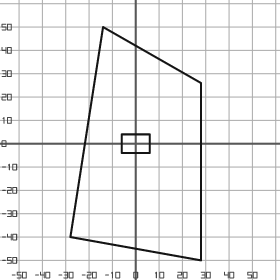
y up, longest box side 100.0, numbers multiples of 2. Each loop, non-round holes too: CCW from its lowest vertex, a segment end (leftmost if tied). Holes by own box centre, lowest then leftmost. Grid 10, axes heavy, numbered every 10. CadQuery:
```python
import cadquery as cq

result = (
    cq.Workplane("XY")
    .moveTo(28.0, -50.0)
    .lineTo(28.0, 26.0)
    .lineTo(-14.0, 50.0)
    .lineTo(-28.0, -40.0)
    .close()
    .moveTo(-6.0, -4.0)
    .lineTo(6.0, -4.0)
    .lineTo(6.0, 4.0)
    .lineTo(-6.0, 4.0)
    .close()
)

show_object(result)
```